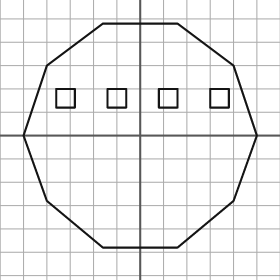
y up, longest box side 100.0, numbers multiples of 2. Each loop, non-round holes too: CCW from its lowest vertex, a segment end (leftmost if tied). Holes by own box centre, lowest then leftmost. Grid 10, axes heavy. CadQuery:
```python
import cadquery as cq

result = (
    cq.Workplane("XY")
    .moveTo(-16.0, -48.0)
    .lineTo(16.0, -48.0)
    .lineTo(40.0, -28.0)
    .lineTo(50.0, 0.0)
    .lineTo(40.0, 30.0)
    .lineTo(16.0, 48.0)
    .lineTo(-16.0, 48.0)
    .lineTo(-40.0, 30.0)
    .lineTo(-50.0, 0.0)
    .lineTo(-40.0, -28.0)
    .close()
    .moveTo(-36.0, 12.0)
    .lineTo(-28.0, 12.0)
    .lineTo(-28.0, 20.0)
    .lineTo(-36.0, 20.0)
    .close()
    .moveTo(-14.0, 12.0)
    .lineTo(-6.0, 12.0)
    .lineTo(-6.0, 20.0)
    .lineTo(-14.0, 20.0)
    .close()
    .moveTo(8.0, 12.0)
    .lineTo(16.0, 12.0)
    .lineTo(16.0, 20.0)
    .lineTo(8.0, 20.0)
    .close()
    .moveTo(30.0, 12.0)
    .lineTo(38.0, 12.0)
    .lineTo(38.0, 20.0)
    .lineTo(30.0, 20.0)
    .close()
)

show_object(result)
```